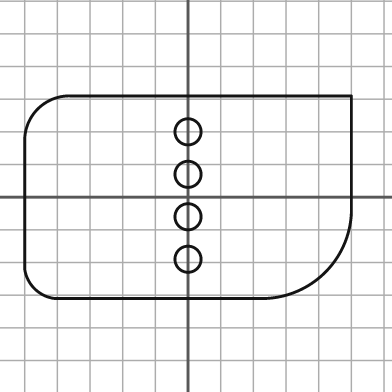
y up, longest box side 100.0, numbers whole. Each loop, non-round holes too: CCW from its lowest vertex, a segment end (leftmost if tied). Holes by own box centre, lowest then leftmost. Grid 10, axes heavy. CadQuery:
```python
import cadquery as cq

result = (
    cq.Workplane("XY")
    .moveTo(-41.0, -31.0)
    .lineTo(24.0, -31.0)
    .threePointArc((42.0, -23.0), (50.0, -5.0))
    .lineTo(50.0, 31.0)
    .lineTo(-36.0, 31.0)
    .threePointArc((-46.0, 27.0), (-50.0, 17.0))
    .lineTo(-50.0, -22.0)
    .threePointArc((-47.0, -28.0), (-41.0, -31.0))
    .close()
    .moveTo(0.0, -19.0)
    .circle(4.0)
    .moveTo(0.0, -6.0)
    .circle(4.0)
    .moveTo(0.0, 7.0)
    .circle(4.0)
    .moveTo(0.0, 20.0)
    .circle(4.0)
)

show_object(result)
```